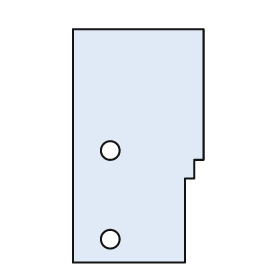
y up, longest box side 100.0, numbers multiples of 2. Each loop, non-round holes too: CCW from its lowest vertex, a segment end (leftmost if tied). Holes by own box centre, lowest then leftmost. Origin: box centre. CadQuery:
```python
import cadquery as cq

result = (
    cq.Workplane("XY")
    .moveTo(-28.0, -50.0)
    .lineTo(20.0, -50.0)
    .lineTo(20.0, -14.0)
    .lineTo(24.0, -14.0)
    .lineTo(24.0, -6.0)
    .lineTo(28.0, -6.0)
    .lineTo(28.0, 50.0)
    .lineTo(-28.0, 50.0)
    .close()
    .moveTo(-12.0, -40.0)
    .circle(4.0)
    .moveTo(-12.0, -2.0)
    .circle(4.0)
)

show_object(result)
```